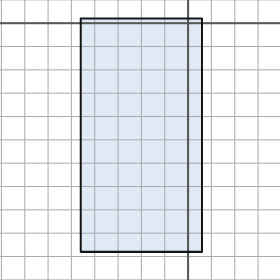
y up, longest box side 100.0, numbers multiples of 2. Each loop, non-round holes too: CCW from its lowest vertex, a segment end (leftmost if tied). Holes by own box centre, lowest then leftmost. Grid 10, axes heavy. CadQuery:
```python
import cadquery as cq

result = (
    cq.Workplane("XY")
    .moveTo(-46.0, -98.0)
    .lineTo(6.0, -98.0)
    .lineTo(6.0, 2.0)
    .lineTo(-46.0, 2.0)
    .close()
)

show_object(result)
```